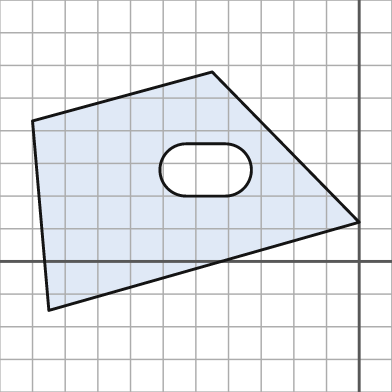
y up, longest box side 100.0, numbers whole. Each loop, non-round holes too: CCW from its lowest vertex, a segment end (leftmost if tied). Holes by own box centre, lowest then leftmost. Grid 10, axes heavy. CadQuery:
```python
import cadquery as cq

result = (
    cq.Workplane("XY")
    .moveTo(-95.0, -15.0)
    .lineTo(0.0, 12.0)
    .lineTo(-45.0, 58.0)
    .lineTo(-100.0, 43.0)
    .close()
    .moveTo(-53.0, 20.0)
    .lineTo(-41.0, 20.0)
    .threePointArc((-33.0, 28.0), (-41.0, 36.0))
    .lineTo(-53.0, 36.0)
    .threePointArc((-61.0, 28.0), (-53.0, 20.0))
    .close()
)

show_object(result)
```